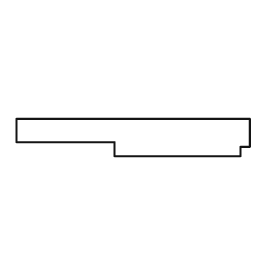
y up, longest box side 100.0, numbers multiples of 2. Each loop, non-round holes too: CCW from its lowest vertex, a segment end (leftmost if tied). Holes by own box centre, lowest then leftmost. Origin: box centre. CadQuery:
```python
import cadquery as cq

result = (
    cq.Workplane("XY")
    .moveTo(-8.0, -8.0)
    .lineTo(46.0, -8.0)
    .lineTo(46.0, -4.0)
    .lineTo(50.0, -4.0)
    .lineTo(50.0, 8.0)
    .lineTo(-50.0, 8.0)
    .lineTo(-50.0, -2.0)
    .lineTo(-8.0, -2.0)
    .close()
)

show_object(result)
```